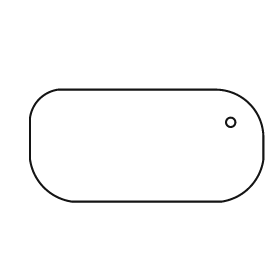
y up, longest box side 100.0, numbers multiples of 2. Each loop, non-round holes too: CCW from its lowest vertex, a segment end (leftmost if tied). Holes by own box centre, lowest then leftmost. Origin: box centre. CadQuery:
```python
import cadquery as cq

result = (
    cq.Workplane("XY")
    .moveTo(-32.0, -24.0)
    .lineTo(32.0, -24.0)
    .threePointArc((44.0, -18.0), (50.0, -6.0))
    .lineTo(50.0, 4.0)
    .threePointArc((44.0, 18.0), (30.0, 24.0))
    .lineTo(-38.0, 24.0)
    .threePointArc((-46.0, 20.0), (-50.0, 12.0))
    .lineTo(-50.0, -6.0)
    .threePointArc((-44.0, -18.0), (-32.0, -24.0))
    .close()
    .moveTo(36.0, 10.0)
    .circle(2.0)
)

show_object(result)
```